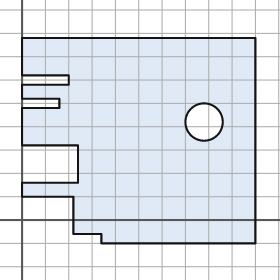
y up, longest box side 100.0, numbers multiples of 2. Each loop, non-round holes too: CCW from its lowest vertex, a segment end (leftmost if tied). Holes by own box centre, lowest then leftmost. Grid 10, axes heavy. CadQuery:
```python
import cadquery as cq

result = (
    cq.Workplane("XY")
    .moveTo(34.0, -10.0)
    .lineTo(100.0, -10.0)
    .lineTo(100.0, 78.0)
    .lineTo(0.0, 78.0)
    .lineTo(0.0, 62.0)
    .lineTo(20.0, 62.0)
    .lineTo(20.0, 58.0)
    .lineTo(0.0, 58.0)
    .lineTo(0.0, 52.0)
    .lineTo(16.0, 52.0)
    .lineTo(16.0, 48.0)
    .lineTo(0.0, 48.0)
    .lineTo(0.0, 32.0)
    .lineTo(24.0, 32.0)
    .lineTo(24.0, 16.0)
    .lineTo(0.0, 16.0)
    .lineTo(0.0, 10.0)
    .lineTo(22.0, 10.0)
    .lineTo(22.0, -6.0)
    .lineTo(34.0, -6.0)
    .close()
    .moveTo(78.0, 42.0)
    .circle(8.0)
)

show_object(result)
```